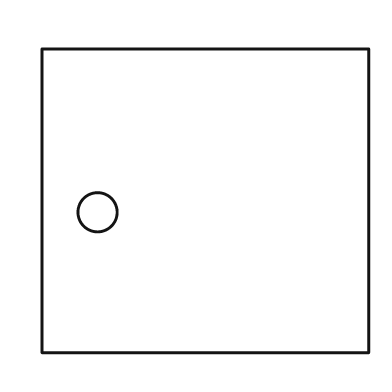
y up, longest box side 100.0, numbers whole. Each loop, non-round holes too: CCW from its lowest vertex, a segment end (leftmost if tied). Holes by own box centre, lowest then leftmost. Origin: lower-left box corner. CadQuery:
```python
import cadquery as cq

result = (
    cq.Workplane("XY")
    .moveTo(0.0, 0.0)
    .lineTo(100.0, 0.0)
    .lineTo(100.0, 93.0)
    .lineTo(0.0, 93.0)
    .close()
    .moveTo(17.0, 43.0)
    .circle(6.0)
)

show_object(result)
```